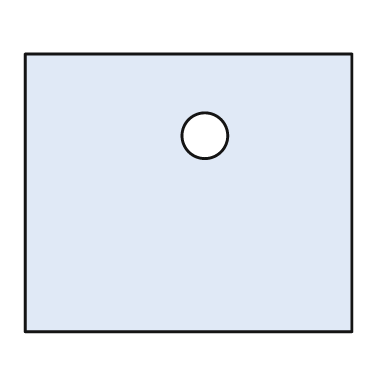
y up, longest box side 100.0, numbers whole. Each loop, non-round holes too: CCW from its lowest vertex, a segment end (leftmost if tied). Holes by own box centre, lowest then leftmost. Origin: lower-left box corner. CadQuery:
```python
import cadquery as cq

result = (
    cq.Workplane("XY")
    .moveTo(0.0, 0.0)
    .lineTo(100.0, 0.0)
    .lineTo(100.0, 85.0)
    .lineTo(0.0, 85.0)
    .close()
    .moveTo(55.0, 60.0)
    .circle(7.0)
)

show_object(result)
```